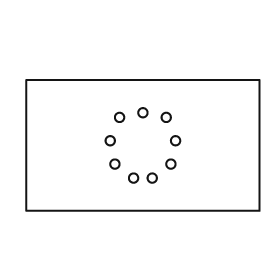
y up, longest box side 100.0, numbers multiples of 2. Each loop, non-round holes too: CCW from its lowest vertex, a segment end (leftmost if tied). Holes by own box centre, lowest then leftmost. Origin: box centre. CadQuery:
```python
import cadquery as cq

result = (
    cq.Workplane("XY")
    .moveTo(-50.0, -28.0)
    .lineTo(50.0, -28.0)
    .lineTo(50.0, 28.0)
    .lineTo(-50.0, 28.0)
    .close()
    .moveTo(-4.0, -14.0)
    .circle(2.0)
    .moveTo(4.0, -14.0)
    .circle(2.0)
    .moveTo(-12.0, -8.0)
    .circle(2.0)
    .moveTo(12.0, -8.0)
    .circle(2.0)
    .moveTo(-14.0, 2.0)
    .circle(2.0)
    .moveTo(14.0, 2.0)
    .circle(2.0)
    .moveTo(-10.0, 12.0)
    .circle(2.0)
    .moveTo(10.0, 12.0)
    .circle(2.0)
    .moveTo(0.0, 14.0)
    .circle(2.0)
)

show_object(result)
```